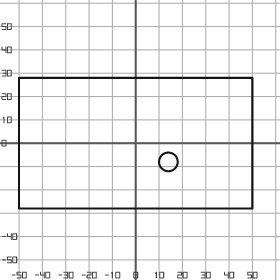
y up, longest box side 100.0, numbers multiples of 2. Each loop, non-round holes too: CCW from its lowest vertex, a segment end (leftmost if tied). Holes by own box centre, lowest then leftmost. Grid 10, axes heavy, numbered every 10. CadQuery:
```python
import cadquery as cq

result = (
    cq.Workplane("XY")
    .moveTo(-50.0, -28.0)
    .lineTo(50.0, -28.0)
    .lineTo(50.0, 28.0)
    .lineTo(-50.0, 28.0)
    .close()
    .moveTo(14.0, -8.0)
    .circle(4.0)
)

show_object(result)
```